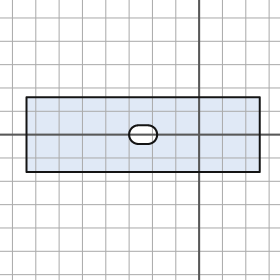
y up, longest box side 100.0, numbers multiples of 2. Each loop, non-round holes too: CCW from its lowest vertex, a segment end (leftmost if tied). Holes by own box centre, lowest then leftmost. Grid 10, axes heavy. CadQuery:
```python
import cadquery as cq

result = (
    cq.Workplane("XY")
    .moveTo(-74.0, -16.0)
    .lineTo(26.0, -16.0)
    .lineTo(26.0, 16.0)
    .lineTo(-74.0, 16.0)
    .close()
    .moveTo(-26.0, -4.0)
    .lineTo(-22.0, -4.0)
    .threePointArc((-18.0, 0.0), (-22.0, 4.0))
    .lineTo(-26.0, 4.0)
    .threePointArc((-30.0, 0.0), (-26.0, -4.0))
    .close()
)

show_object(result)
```